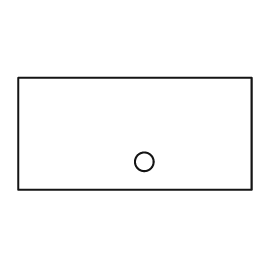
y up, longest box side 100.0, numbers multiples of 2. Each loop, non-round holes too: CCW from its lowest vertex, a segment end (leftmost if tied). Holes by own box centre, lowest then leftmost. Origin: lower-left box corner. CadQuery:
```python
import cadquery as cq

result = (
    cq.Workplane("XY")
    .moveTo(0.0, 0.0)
    .lineTo(100.0, 0.0)
    .lineTo(100.0, 48.0)
    .lineTo(0.0, 48.0)
    .close()
    .moveTo(54.0, 12.0)
    .circle(4.0)
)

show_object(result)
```